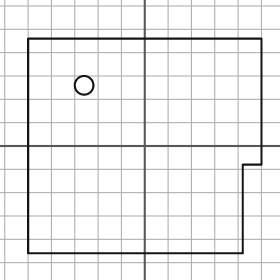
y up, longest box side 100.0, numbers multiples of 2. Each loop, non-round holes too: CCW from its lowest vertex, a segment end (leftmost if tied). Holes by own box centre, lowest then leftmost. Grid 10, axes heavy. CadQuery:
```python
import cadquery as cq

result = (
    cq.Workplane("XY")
    .moveTo(-50.0, -46.0)
    .lineTo(42.0, -46.0)
    .lineTo(42.0, -8.0)
    .lineTo(50.0, -8.0)
    .lineTo(50.0, 46.0)
    .lineTo(-50.0, 46.0)
    .close()
    .moveTo(-26.0, 26.0)
    .circle(4.0)
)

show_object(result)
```